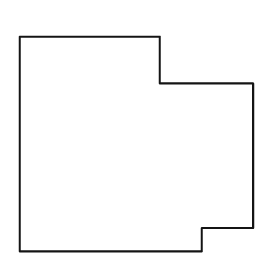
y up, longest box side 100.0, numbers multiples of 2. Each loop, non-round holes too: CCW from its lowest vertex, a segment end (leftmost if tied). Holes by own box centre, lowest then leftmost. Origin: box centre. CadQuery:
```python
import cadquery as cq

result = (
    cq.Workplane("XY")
    .moveTo(-50.0, -46.0)
    .lineTo(28.0, -46.0)
    .lineTo(28.0, -36.0)
    .lineTo(50.0, -36.0)
    .lineTo(50.0, 26.0)
    .lineTo(10.0, 26.0)
    .lineTo(10.0, 46.0)
    .lineTo(-50.0, 46.0)
    .close()
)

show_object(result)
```